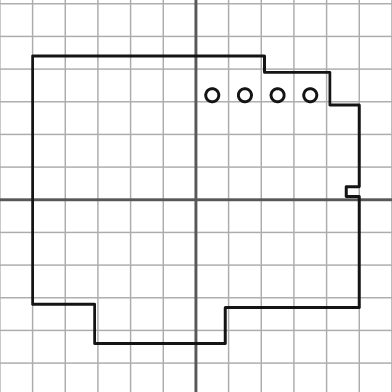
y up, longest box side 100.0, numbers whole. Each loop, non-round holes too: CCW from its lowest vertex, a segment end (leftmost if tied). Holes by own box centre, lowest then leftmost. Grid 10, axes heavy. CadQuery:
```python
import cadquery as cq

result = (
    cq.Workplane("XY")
    .moveTo(-31.0, -44.0)
    .lineTo(9.0, -44.0)
    .lineTo(9.0, -33.0)
    .lineTo(50.0, -33.0)
    .lineTo(50.0, 1.0)
    .lineTo(46.0, 1.0)
    .lineTo(46.0, 4.0)
    .lineTo(50.0, 4.0)
    .lineTo(50.0, 29.0)
    .lineTo(41.0, 29.0)
    .lineTo(41.0, 39.0)
    .lineTo(21.0, 39.0)
    .lineTo(21.0, 44.0)
    .lineTo(-50.0, 44.0)
    .lineTo(-50.0, -32.0)
    .lineTo(-31.0, -32.0)
    .close()
    .moveTo(5.0, 32.0)
    .circle(2.0)
    .moveTo(15.0, 32.0)
    .circle(2.0)
    .moveTo(25.0, 32.0)
    .circle(2.0)
    .moveTo(35.0, 32.0)
    .circle(2.0)
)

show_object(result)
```